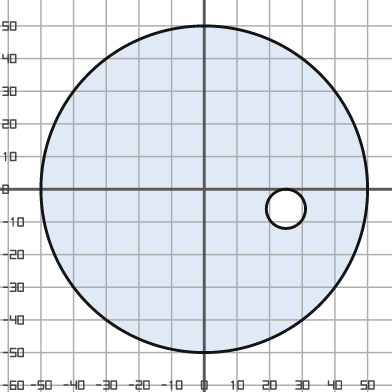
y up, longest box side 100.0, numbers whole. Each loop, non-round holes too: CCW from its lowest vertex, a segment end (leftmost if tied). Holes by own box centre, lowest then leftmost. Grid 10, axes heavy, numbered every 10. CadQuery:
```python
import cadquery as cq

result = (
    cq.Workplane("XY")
    .moveTo(0.0, 0.0)
    .circle(50.0)
    .moveTo(25.0, -6.0)
    .circle(6.0)
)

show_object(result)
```